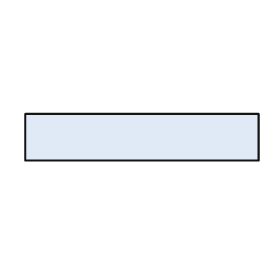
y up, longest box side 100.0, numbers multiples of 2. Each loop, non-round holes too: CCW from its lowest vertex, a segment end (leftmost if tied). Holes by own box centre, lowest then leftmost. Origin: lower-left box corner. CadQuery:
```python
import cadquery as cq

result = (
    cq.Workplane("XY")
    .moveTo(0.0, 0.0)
    .lineTo(100.0, 0.0)
    .lineTo(100.0, 20.0)
    .lineTo(0.0, 20.0)
    .close()
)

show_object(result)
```